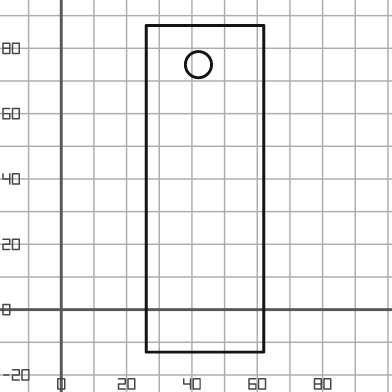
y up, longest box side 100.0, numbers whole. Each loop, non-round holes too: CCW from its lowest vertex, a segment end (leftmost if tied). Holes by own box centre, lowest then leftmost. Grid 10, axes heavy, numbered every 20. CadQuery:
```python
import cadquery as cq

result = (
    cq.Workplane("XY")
    .moveTo(26.0, -13.0)
    .lineTo(62.0, -13.0)
    .lineTo(62.0, 87.0)
    .lineTo(26.0, 87.0)
    .close()
    .moveTo(42.0, 75.0)
    .circle(4.0)
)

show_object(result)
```